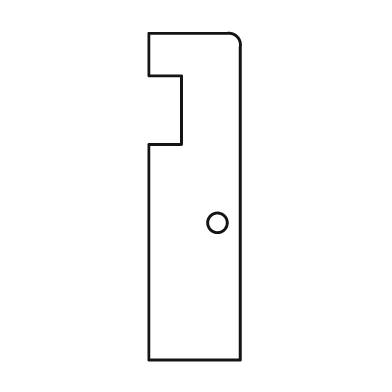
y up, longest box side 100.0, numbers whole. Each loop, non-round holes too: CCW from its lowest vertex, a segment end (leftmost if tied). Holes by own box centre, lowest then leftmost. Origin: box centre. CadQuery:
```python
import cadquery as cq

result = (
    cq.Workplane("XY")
    .moveTo(-14.0, -50.0)
    .lineTo(14.0, -50.0)
    .lineTo(14.0, 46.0)
    .threePointArc((13.0, 49.0), (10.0, 50.0))
    .lineTo(-14.0, 50.0)
    .lineTo(-14.0, 37.0)
    .lineTo(-4.0, 37.0)
    .lineTo(-4.0, 16.0)
    .lineTo(-14.0, 16.0)
    .close()
    .moveTo(7.0, -8.0)
    .circle(3.0)
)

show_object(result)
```